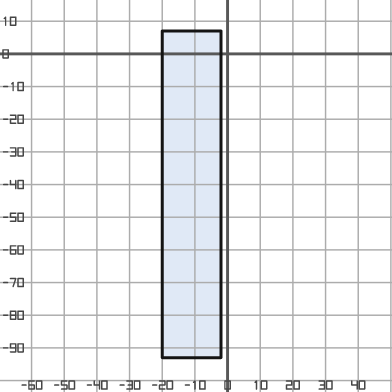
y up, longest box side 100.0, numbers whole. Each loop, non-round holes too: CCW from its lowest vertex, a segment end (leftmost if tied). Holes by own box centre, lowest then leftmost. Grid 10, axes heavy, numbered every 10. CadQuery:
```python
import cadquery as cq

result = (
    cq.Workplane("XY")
    .moveTo(-20.0, -93.0)
    .lineTo(-2.0, -93.0)
    .lineTo(-2.0, 7.0)
    .lineTo(-20.0, 7.0)
    .close()
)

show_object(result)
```